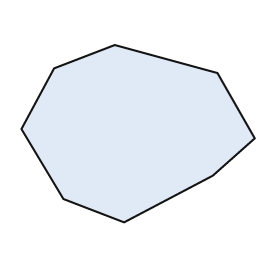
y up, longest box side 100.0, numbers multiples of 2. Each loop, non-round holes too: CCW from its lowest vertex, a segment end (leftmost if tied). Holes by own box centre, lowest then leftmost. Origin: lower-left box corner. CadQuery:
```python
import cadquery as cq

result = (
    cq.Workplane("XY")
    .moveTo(44.0, 0.0)
    .lineTo(82.0, 20.0)
    .lineTo(100.0, 36.0)
    .lineTo(84.0, 64.0)
    .lineTo(40.0, 76.0)
    .lineTo(14.0, 66.0)
    .lineTo(0.0, 40.0)
    .lineTo(18.0, 10.0)
    .close()
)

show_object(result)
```